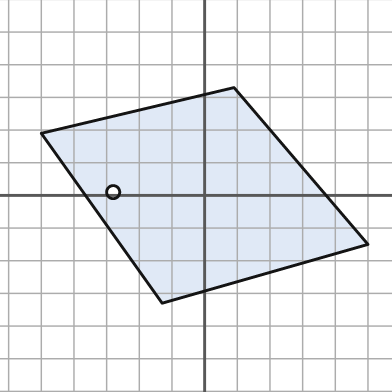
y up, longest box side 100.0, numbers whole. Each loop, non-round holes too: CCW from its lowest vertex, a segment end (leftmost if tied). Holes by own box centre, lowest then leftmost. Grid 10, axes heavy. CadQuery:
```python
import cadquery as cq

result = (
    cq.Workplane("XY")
    .moveTo(-13.0, -33.0)
    .lineTo(50.0, -15.0)
    .lineTo(9.0, 33.0)
    .lineTo(-50.0, 19.0)
    .close()
    .moveTo(-28.0, 1.0)
    .circle(2.0)
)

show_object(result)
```